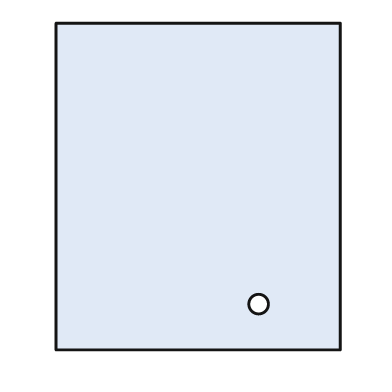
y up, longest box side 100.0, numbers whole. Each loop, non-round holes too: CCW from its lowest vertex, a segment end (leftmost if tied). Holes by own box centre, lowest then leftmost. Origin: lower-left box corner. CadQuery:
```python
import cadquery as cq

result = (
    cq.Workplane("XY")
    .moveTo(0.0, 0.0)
    .lineTo(87.0, 0.0)
    .lineTo(87.0, 100.0)
    .lineTo(0.0, 100.0)
    .close()
    .moveTo(62.0, 14.0)
    .circle(3.0)
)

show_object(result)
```